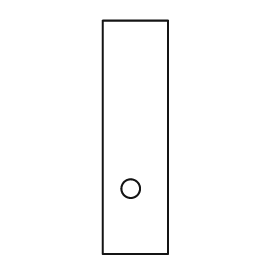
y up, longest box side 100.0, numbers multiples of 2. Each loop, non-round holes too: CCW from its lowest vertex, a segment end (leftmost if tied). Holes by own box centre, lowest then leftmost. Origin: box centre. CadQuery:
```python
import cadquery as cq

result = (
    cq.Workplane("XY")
    .moveTo(-14.0, -50.0)
    .lineTo(14.0, -50.0)
    .lineTo(14.0, 50.0)
    .lineTo(-14.0, 50.0)
    .close()
    .moveTo(-2.0, -22.0)
    .circle(4.0)
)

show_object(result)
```